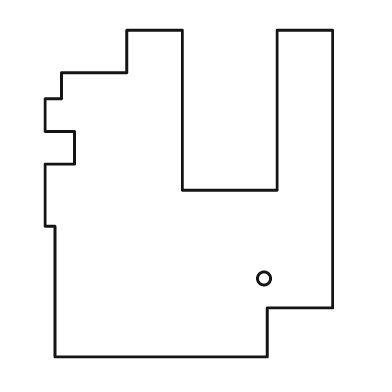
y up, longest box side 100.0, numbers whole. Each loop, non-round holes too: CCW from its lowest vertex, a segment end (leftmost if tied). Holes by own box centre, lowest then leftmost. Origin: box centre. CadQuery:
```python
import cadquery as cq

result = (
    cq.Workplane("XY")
    .moveTo(-41.0, -50.0)
    .lineTo(24.0, -50.0)
    .lineTo(24.0, -35.0)
    .lineTo(44.0, -35.0)
    .lineTo(44.0, 50.0)
    .lineTo(27.0, 50.0)
    .lineTo(27.0, 1.0)
    .lineTo(-2.0, 1.0)
    .lineTo(-2.0, 50.0)
    .lineTo(-19.0, 50.0)
    .lineTo(-19.0, 37.0)
    .lineTo(-39.0, 37.0)
    .lineTo(-39.0, 29.0)
    .lineTo(-44.0, 29.0)
    .lineTo(-44.0, 19.0)
    .lineTo(-35.0, 19.0)
    .lineTo(-35.0, 9.0)
    .lineTo(-44.0, 9.0)
    .lineTo(-44.0, -10.0)
    .lineTo(-41.0, -10.0)
    .close()
    .moveTo(23.0, -26.0)
    .circle(2.0)
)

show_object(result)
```